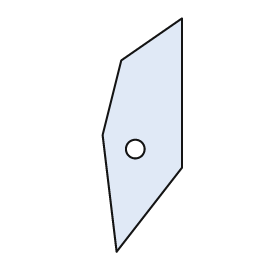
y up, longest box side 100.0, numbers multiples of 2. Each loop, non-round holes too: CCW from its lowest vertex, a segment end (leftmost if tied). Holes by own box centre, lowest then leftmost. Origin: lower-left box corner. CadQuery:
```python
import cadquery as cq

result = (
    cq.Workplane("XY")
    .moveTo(6.0, 0.0)
    .lineTo(34.0, 36.0)
    .lineTo(34.0, 100.0)
    .lineTo(8.0, 82.0)
    .lineTo(0.0, 50.0)
    .close()
    .moveTo(14.0, 44.0)
    .circle(4.0)
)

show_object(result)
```